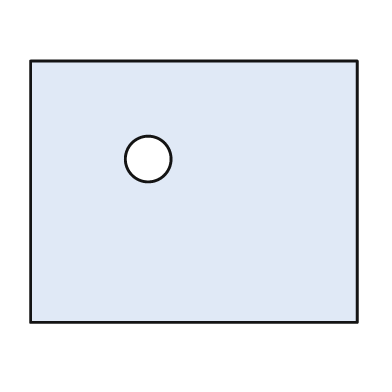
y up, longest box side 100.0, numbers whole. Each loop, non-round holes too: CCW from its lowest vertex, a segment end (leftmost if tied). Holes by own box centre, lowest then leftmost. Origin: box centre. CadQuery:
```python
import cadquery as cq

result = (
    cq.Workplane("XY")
    .moveTo(-50.0, -40.0)
    .lineTo(50.0, -40.0)
    .lineTo(50.0, 40.0)
    .lineTo(-50.0, 40.0)
    .close()
    .moveTo(-14.0, 10.0)
    .circle(7.0)
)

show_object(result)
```